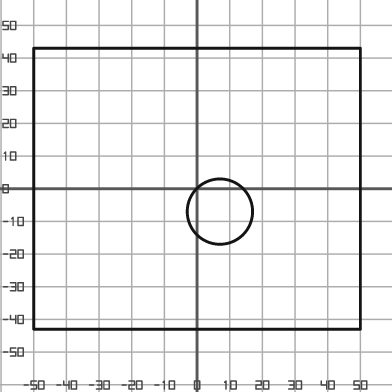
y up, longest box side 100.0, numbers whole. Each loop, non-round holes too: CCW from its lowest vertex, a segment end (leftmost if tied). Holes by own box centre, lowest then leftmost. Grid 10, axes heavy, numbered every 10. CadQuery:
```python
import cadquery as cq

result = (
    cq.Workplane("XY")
    .moveTo(-50.0, -43.0)
    .lineTo(50.0, -43.0)
    .lineTo(50.0, 43.0)
    .lineTo(-50.0, 43.0)
    .close()
    .moveTo(7.0, -7.0)
    .circle(10.0)
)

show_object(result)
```